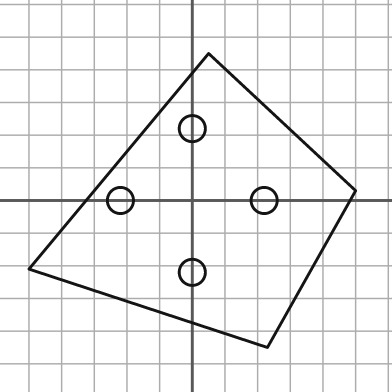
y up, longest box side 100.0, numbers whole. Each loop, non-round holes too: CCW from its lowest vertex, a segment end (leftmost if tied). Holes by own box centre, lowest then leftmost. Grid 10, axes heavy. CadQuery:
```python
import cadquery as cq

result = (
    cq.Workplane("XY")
    .moveTo(23.0, -45.0)
    .lineTo(50.0, 3.0)
    .lineTo(5.0, 45.0)
    .lineTo(-50.0, -21.0)
    .close()
    .moveTo(0.0, -22.0)
    .circle(4.0)
    .moveTo(-22.0, 0.0)
    .circle(4.0)
    .moveTo(22.0, 0.0)
    .circle(4.0)
    .moveTo(0.0, 22.0)
    .circle(4.0)
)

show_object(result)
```